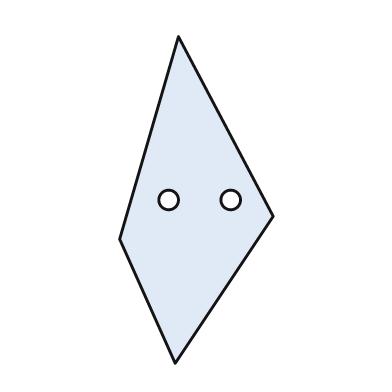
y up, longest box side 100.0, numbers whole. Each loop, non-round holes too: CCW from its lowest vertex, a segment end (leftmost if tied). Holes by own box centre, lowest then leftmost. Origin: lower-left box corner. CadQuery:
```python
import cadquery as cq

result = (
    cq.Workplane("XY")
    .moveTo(17.0, 0.0)
    .lineTo(47.0, 45.0)
    .lineTo(18.0, 100.0)
    .lineTo(0.0, 38.0)
    .close()
    .moveTo(15.0, 50.0)
    .circle(3.0)
    .moveTo(34.0, 50.0)
    .circle(3.0)
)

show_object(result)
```